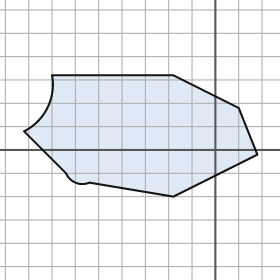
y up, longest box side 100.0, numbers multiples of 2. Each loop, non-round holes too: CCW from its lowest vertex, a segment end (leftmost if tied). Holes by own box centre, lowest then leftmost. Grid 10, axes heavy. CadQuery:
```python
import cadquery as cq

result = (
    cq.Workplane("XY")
    .moveTo(-18.0, -20.0)
    .lineTo(18.0, -2.0)
    .lineTo(10.0, 18.0)
    .lineTo(-18.0, 32.0)
    .lineTo(-70.0, 32.0)
    .threePointArc((-72.0, 18.0), (-82.0, 8.0))
    .lineTo(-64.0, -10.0)
    .threePointArc((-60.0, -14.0), (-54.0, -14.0))
    .close()
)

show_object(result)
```